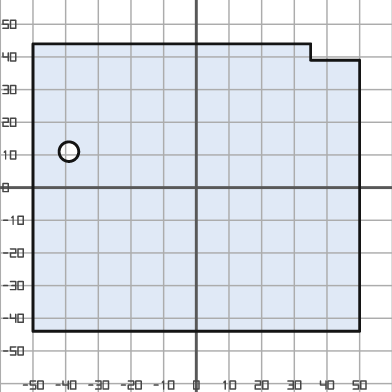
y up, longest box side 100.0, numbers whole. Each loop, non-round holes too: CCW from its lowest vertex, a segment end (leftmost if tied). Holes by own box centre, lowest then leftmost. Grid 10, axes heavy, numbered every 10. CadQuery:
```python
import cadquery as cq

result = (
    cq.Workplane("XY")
    .moveTo(-50.0, -44.0)
    .lineTo(50.0, -44.0)
    .lineTo(50.0, 39.0)
    .lineTo(35.0, 39.0)
    .lineTo(35.0, 44.0)
    .lineTo(-50.0, 44.0)
    .close()
    .moveTo(-39.0, 11.0)
    .circle(3.0)
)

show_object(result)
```